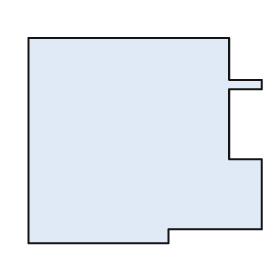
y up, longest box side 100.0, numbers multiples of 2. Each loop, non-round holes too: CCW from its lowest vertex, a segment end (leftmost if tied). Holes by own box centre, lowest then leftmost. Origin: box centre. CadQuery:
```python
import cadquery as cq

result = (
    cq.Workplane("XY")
    .moveTo(-50.0, -44.0)
    .lineTo(10.0, -44.0)
    .lineTo(10.0, -38.0)
    .lineTo(50.0, -38.0)
    .lineTo(50.0, -8.0)
    .lineTo(36.0, -8.0)
    .lineTo(36.0, 22.0)
    .lineTo(50.0, 22.0)
    .lineTo(50.0, 26.0)
    .lineTo(36.0, 26.0)
    .lineTo(36.0, 44.0)
    .lineTo(-50.0, 44.0)
    .close()
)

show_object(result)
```